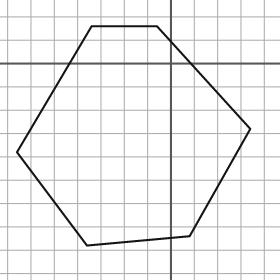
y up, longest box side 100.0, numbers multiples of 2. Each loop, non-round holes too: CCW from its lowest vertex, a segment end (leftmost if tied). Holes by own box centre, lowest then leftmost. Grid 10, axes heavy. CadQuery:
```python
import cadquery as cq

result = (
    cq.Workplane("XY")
    .moveTo(-36.0, -78.0)
    .lineTo(8.0, -74.0)
    .lineTo(34.0, -28.0)
    .lineTo(-6.0, 16.0)
    .lineTo(-34.0, 16.0)
    .lineTo(-66.0, -38.0)
    .close()
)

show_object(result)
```